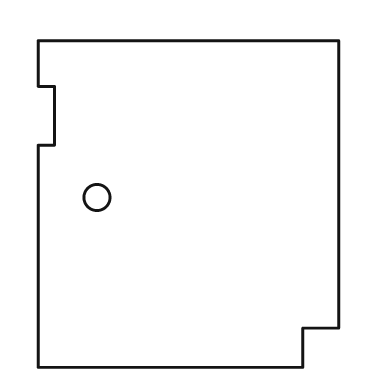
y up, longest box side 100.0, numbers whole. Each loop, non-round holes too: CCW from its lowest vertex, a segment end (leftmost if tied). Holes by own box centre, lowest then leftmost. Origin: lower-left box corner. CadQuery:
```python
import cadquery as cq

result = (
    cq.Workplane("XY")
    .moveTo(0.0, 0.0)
    .lineTo(81.0, 0.0)
    .lineTo(81.0, 12.0)
    .lineTo(92.0, 12.0)
    .lineTo(92.0, 100.0)
    .lineTo(0.0, 100.0)
    .lineTo(0.0, 86.0)
    .lineTo(5.0, 86.0)
    .lineTo(5.0, 68.0)
    .lineTo(0.0, 68.0)
    .close()
    .moveTo(18.0, 52.0)
    .circle(4.0)
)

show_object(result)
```